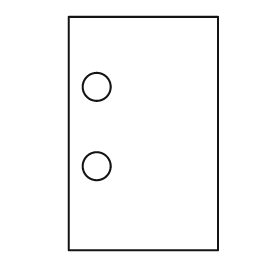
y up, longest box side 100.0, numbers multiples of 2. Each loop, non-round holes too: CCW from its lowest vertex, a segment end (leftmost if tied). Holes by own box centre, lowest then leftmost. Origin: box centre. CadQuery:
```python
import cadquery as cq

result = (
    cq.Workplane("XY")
    .moveTo(-32.0, -50.0)
    .lineTo(32.0, -50.0)
    .lineTo(32.0, 50.0)
    .lineTo(-32.0, 50.0)
    .close()
    .moveTo(-20.0, -14.0)
    .circle(6.0)
    .moveTo(-20.0, 20.0)
    .circle(6.0)
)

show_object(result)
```